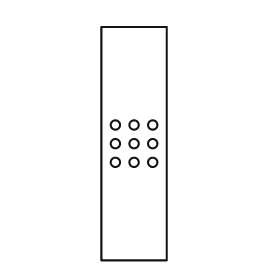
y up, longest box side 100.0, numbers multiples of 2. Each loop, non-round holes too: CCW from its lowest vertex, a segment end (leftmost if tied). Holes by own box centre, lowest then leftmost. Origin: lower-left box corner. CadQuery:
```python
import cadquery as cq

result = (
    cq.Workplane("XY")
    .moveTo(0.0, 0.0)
    .lineTo(28.0, 0.0)
    .lineTo(28.0, 100.0)
    .lineTo(0.0, 100.0)
    .close()
    .moveTo(6.0, 42.0)
    .circle(2.0)
    .moveTo(14.0, 42.0)
    .circle(2.0)
    .moveTo(22.0, 42.0)
    .circle(2.0)
    .moveTo(6.0, 50.0)
    .circle(2.0)
    .moveTo(14.0, 50.0)
    .circle(2.0)
    .moveTo(22.0, 50.0)
    .circle(2.0)
    .moveTo(6.0, 58.0)
    .circle(2.0)
    .moveTo(14.0, 58.0)
    .circle(2.0)
    .moveTo(22.0, 58.0)
    .circle(2.0)
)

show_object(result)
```